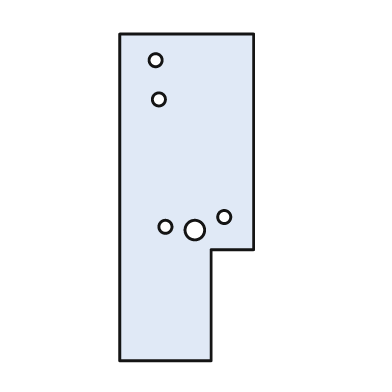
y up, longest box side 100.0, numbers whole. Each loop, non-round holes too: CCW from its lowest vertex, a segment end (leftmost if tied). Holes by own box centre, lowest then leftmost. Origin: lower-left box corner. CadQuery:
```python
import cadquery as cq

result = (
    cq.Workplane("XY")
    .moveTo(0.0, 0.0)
    .lineTo(28.0, 0.0)
    .lineTo(28.0, 34.0)
    .lineTo(41.0, 34.0)
    .lineTo(41.0, 100.0)
    .lineTo(0.0, 100.0)
    .close()
    .moveTo(23.0, 40.0)
    .circle(3.0)
    .moveTo(14.0, 41.0)
    .circle(2.0)
    .moveTo(32.0, 44.0)
    .circle(2.0)
    .moveTo(12.0, 80.0)
    .circle(2.0)
    .moveTo(11.0, 92.0)
    .circle(2.0)
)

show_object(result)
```